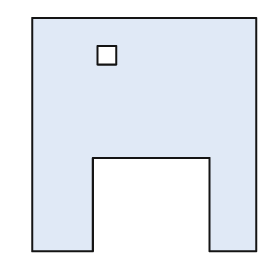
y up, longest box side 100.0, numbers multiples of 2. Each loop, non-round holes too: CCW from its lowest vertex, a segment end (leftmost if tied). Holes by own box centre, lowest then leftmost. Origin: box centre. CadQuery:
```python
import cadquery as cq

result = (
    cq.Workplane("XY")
    .moveTo(-48.0, -50.0)
    .lineTo(-22.0, -50.0)
    .lineTo(-22.0, -10.0)
    .lineTo(28.0, -10.0)
    .lineTo(28.0, -50.0)
    .lineTo(48.0, -50.0)
    .lineTo(48.0, 50.0)
    .lineTo(-48.0, 50.0)
    .close()
    .moveTo(-20.0, 30.0)
    .lineTo(-12.0, 30.0)
    .lineTo(-12.0, 38.0)
    .lineTo(-20.0, 38.0)
    .close()
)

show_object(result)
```